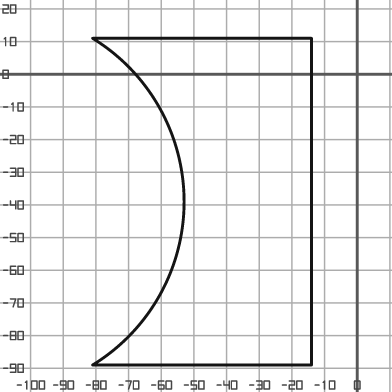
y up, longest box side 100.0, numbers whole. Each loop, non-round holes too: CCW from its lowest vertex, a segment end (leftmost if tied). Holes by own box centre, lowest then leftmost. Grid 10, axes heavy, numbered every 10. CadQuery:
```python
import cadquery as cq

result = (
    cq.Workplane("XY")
    .moveTo(-81.0, -89.0)
    .lineTo(-14.0, -89.0)
    .lineTo(-14.0, 11.0)
    .lineTo(-81.0, 11.0)
    .threePointArc((-53.0, -39.0), (-81.0, -89.0))
    .close()
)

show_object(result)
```